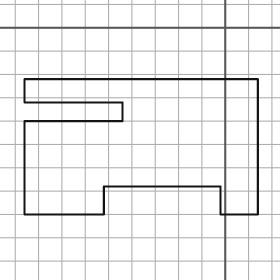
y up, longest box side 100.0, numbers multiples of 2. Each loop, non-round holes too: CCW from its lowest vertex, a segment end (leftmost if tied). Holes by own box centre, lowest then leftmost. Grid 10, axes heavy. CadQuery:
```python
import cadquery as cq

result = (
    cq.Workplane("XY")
    .moveTo(-86.0, -80.0)
    .lineTo(-52.0, -80.0)
    .lineTo(-52.0, -68.0)
    .lineTo(-2.0, -68.0)
    .lineTo(-2.0, -80.0)
    .lineTo(14.0, -80.0)
    .lineTo(14.0, -22.0)
    .lineTo(-86.0, -22.0)
    .lineTo(-86.0, -32.0)
    .lineTo(-44.0, -32.0)
    .lineTo(-44.0, -40.0)
    .lineTo(-86.0, -40.0)
    .close()
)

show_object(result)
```